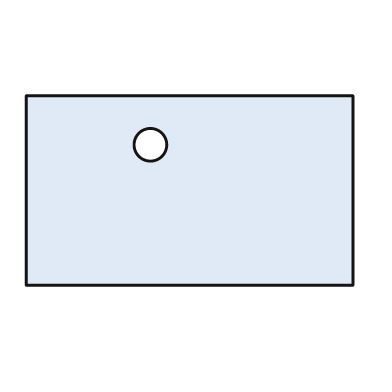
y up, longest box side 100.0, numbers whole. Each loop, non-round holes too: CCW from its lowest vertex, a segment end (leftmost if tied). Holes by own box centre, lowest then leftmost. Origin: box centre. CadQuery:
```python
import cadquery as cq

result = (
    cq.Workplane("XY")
    .moveTo(-50.0, -29.0)
    .lineTo(50.0, -29.0)
    .lineTo(50.0, 29.0)
    .lineTo(-50.0, 29.0)
    .close()
    .moveTo(-12.0, 14.0)
    .circle(5.0)
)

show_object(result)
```